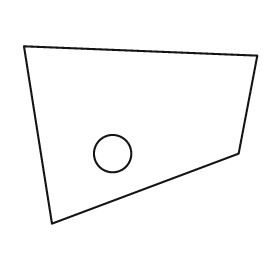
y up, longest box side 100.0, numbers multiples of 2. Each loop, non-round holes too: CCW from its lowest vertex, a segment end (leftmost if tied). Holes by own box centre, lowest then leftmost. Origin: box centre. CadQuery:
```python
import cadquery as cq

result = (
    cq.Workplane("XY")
    .moveTo(-38.0, -38.0)
    .lineTo(42.0, -8.0)
    .lineTo(50.0, 34.0)
    .lineTo(-50.0, 38.0)
    .close()
    .moveTo(-12.0, -8.0)
    .circle(8.0)
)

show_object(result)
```